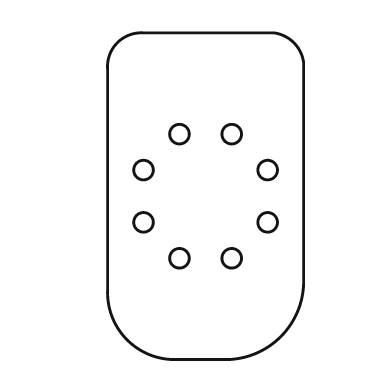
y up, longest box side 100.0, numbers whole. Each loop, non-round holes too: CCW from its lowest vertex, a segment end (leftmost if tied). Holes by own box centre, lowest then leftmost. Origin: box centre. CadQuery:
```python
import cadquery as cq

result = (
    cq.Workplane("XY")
    .moveTo(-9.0, -50.0)
    .lineTo(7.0, -50.0)
    .threePointArc((23.0, -43.0), (30.0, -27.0))
    .lineTo(30.0, 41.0)
    .threePointArc((27.0, 47.0), (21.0, 50.0))
    .lineTo(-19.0, 50.0)
    .threePointArc((-27.0, 47.0), (-30.0, 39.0))
    .lineTo(-30.0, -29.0)
    .threePointArc((-24.0, -44.0), (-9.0, -50.0))
    .close()
    .moveTo(-8.0, -19.0)
    .circle(3.0)
    .moveTo(8.0, -19.0)
    .circle(3.0)
    .moveTo(-19.0, -8.0)
    .circle(3.0)
    .moveTo(19.0, -8.0)
    .circle(3.0)
    .moveTo(-19.0, 8.0)
    .circle(3.0)
    .moveTo(19.0, 8.0)
    .circle(3.0)
    .moveTo(-8.0, 19.0)
    .circle(3.0)
    .moveTo(8.0, 19.0)
    .circle(3.0)
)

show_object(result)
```